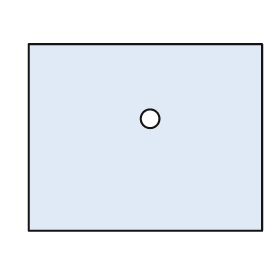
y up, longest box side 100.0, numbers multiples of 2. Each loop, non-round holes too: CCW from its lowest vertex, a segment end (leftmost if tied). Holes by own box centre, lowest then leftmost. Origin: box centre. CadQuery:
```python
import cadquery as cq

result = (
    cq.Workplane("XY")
    .moveTo(-50.0, -40.0)
    .lineTo(50.0, -40.0)
    .lineTo(50.0, 40.0)
    .lineTo(-50.0, 40.0)
    .close()
    .moveTo(2.0, 8.0)
    .circle(4.0)
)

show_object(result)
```